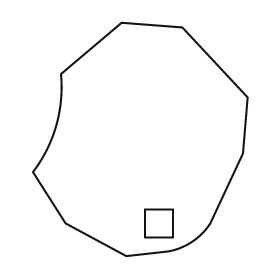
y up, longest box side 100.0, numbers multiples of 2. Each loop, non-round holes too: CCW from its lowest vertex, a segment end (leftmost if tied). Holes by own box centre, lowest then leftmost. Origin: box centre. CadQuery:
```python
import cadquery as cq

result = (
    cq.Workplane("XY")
    .moveTo(-6.0, -50.0)
    .lineTo(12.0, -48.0)
    .threePointArc((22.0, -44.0), (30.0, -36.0))
    .lineTo(44.0, -6.0)
    .lineTo(46.0, 18.0)
    .lineTo(18.0, 48.0)
    .lineTo(-8.0, 50.0)
    .lineTo(-34.0, 28.0)
    .threePointArc((-36.0, 6.0), (-46.0, -14.0))
    .lineTo(-32.0, -36.0)
    .close()
    .moveTo(2.0, -42.0)
    .lineTo(14.0, -42.0)
    .lineTo(14.0, -30.0)
    .lineTo(2.0, -30.0)
    .close()
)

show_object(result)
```